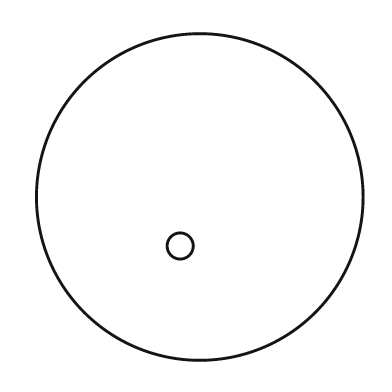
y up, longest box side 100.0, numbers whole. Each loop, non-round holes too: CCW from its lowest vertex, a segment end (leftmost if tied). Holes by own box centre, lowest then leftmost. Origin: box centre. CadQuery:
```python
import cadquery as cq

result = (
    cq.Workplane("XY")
    .moveTo(0.0, 0.0)
    .circle(50.0)
    .moveTo(-6.0, -15.0)
    .circle(4.0)
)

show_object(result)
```